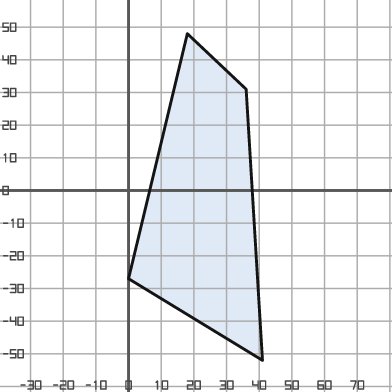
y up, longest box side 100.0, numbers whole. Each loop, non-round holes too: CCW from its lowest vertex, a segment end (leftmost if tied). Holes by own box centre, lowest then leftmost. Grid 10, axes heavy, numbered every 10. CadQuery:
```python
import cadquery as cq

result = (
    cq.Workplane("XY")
    .moveTo(41.0, -52.0)
    .lineTo(36.0, 31.0)
    .lineTo(18.0, 48.0)
    .lineTo(0.0, -27.0)
    .close()
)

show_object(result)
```